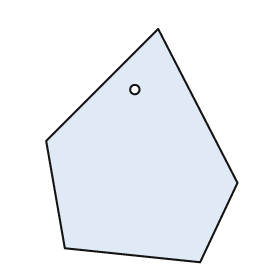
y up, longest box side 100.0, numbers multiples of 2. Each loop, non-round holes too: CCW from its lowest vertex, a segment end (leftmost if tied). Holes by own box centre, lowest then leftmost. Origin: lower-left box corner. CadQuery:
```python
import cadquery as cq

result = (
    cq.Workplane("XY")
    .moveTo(66.0, 0.0)
    .lineTo(82.0, 34.0)
    .lineTo(48.0, 100.0)
    .lineTo(0.0, 52.0)
    .lineTo(8.0, 6.0)
    .close()
    .moveTo(38.0, 74.0)
    .circle(2.0)
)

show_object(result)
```